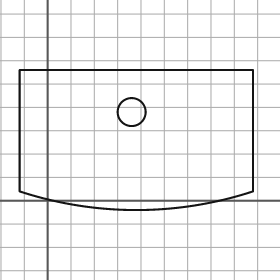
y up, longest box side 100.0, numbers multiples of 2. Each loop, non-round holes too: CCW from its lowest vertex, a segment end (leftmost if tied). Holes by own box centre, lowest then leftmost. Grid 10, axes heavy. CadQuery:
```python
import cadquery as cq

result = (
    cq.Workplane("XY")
    .moveTo(-12.0, 4.0)
    .threePointArc((38.0, -4.0), (88.0, 4.0))
    .lineTo(88.0, 56.0)
    .lineTo(-12.0, 56.0)
    .close()
    .moveTo(36.0, 38.0)
    .circle(6.0)
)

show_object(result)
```